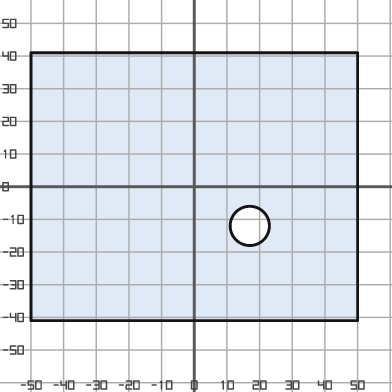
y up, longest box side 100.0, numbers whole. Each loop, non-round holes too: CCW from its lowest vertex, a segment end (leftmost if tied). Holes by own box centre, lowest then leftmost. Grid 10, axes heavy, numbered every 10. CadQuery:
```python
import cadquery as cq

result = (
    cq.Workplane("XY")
    .moveTo(-50.0, -41.0)
    .lineTo(50.0, -41.0)
    .lineTo(50.0, 41.0)
    .lineTo(-50.0, 41.0)
    .close()
    .moveTo(17.0, -12.0)
    .circle(6.0)
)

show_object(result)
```